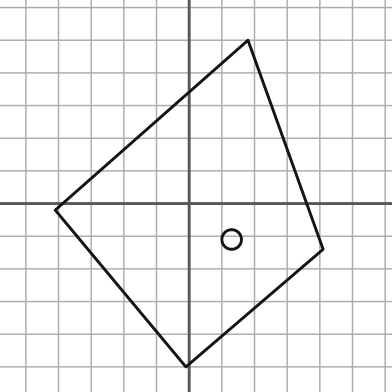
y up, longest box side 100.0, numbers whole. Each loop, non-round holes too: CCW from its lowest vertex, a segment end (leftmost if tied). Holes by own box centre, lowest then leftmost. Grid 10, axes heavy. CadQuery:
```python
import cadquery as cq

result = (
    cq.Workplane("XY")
    .moveTo(-1.0, -50.0)
    .lineTo(41.0, -14.0)
    .lineTo(18.0, 50.0)
    .lineTo(-41.0, -2.0)
    .close()
    .moveTo(13.0, -11.0)
    .circle(3.0)
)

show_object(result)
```